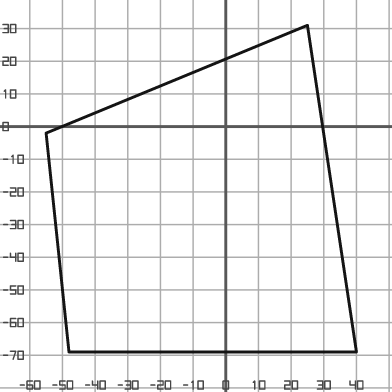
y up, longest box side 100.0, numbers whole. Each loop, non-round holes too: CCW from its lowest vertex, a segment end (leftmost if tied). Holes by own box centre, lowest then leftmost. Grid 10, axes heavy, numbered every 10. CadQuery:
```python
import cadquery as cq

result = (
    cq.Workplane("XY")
    .moveTo(-48.0, -69.0)
    .lineTo(40.0, -69.0)
    .lineTo(25.0, 31.0)
    .lineTo(-55.0, -2.0)
    .close()
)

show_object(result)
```